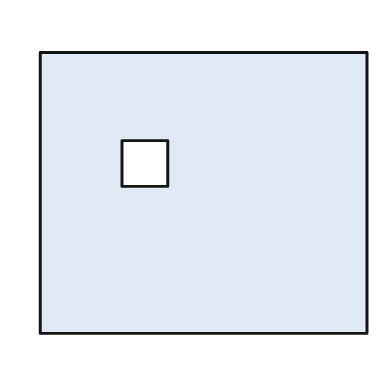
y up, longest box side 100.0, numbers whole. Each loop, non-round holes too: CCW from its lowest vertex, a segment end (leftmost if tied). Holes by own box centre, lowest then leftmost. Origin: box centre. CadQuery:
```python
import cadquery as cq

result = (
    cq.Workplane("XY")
    .moveTo(-50.0, -43.0)
    .lineTo(50.0, -43.0)
    .lineTo(50.0, 43.0)
    .lineTo(-50.0, 43.0)
    .close()
    .moveTo(-25.0, 2.0)
    .lineTo(-11.0, 2.0)
    .lineTo(-11.0, 16.0)
    .lineTo(-25.0, 16.0)
    .close()
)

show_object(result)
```